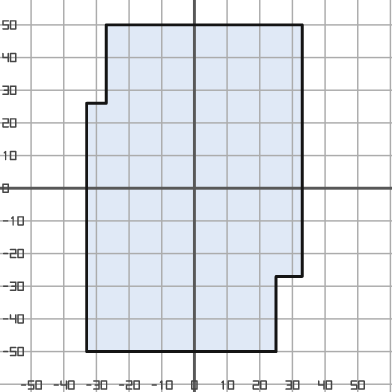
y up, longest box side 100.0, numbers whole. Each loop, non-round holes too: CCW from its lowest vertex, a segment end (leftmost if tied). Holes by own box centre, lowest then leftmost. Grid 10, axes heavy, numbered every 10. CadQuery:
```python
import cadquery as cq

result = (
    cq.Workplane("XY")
    .moveTo(-33.0, -50.0)
    .lineTo(25.0, -50.0)
    .lineTo(25.0, -27.0)
    .lineTo(33.0, -27.0)
    .lineTo(33.0, 50.0)
    .lineTo(-27.0, 50.0)
    .lineTo(-27.0, 26.0)
    .lineTo(-33.0, 26.0)
    .close()
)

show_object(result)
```